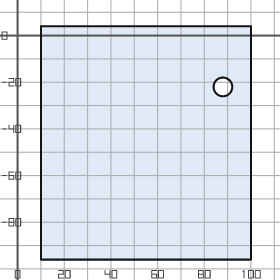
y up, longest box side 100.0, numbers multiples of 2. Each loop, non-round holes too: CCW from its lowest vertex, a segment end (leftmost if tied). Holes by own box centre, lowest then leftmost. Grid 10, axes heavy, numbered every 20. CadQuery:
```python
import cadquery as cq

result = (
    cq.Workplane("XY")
    .moveTo(10.0, -96.0)
    .lineTo(100.0, -96.0)
    .lineTo(100.0, 4.0)
    .lineTo(10.0, 4.0)
    .close()
    .moveTo(88.0, -22.0)
    .circle(4.0)
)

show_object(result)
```